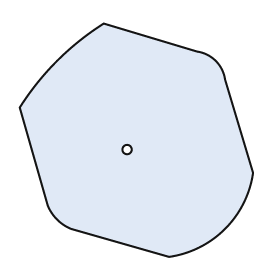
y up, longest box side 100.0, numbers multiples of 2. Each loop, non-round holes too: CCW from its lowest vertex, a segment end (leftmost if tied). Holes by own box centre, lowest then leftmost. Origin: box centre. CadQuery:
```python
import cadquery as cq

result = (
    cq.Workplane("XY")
    .moveTo(14.0, -50.0)
    .threePointArc((38.0, -38.0), (50.0, -14.0))
    .lineTo(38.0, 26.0)
    .threePointArc((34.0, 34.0), (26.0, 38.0))
    .lineTo(-14.0, 50.0)
    .threePointArc((-34.0, 34.0), (-50.0, 14.0))
    .lineTo(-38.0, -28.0)
    .threePointArc((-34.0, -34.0), (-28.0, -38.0))
    .close()
    .moveTo(-4.0, -4.0)
    .circle(2.0)
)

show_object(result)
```